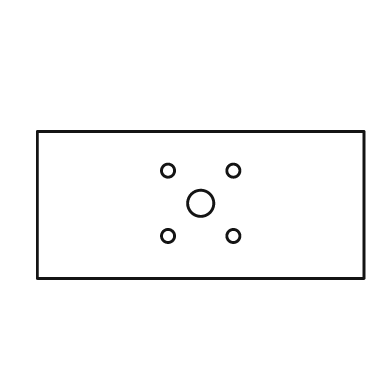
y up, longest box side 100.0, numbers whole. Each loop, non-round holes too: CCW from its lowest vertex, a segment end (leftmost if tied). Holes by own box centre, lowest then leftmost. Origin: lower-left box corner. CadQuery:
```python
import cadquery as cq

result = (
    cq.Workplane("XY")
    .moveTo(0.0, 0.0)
    .lineTo(100.0, 0.0)
    .lineTo(100.0, 45.0)
    .lineTo(0.0, 45.0)
    .close()
    .moveTo(40.0, 13.0)
    .circle(2.0)
    .moveTo(60.0, 13.0)
    .circle(2.0)
    .moveTo(50.0, 23.0)
    .circle(4.0)
    .moveTo(40.0, 33.0)
    .circle(2.0)
    .moveTo(60.0, 33.0)
    .circle(2.0)
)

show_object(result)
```